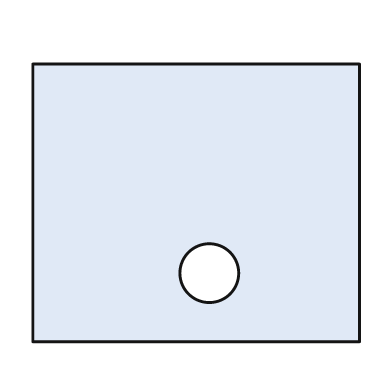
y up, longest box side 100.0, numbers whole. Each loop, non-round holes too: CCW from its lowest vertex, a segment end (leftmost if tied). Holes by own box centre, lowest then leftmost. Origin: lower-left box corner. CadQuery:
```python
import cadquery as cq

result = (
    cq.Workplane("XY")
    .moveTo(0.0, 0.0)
    .lineTo(100.0, 0.0)
    .lineTo(100.0, 85.0)
    .lineTo(0.0, 85.0)
    .close()
    .moveTo(54.0, 21.0)
    .circle(9.0)
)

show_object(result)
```